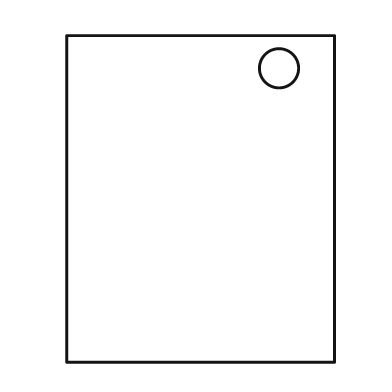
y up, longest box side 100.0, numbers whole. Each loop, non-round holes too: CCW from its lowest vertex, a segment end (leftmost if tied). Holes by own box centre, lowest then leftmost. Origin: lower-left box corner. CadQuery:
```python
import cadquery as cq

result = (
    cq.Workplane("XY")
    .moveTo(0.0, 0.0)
    .lineTo(82.0, 0.0)
    .lineTo(82.0, 100.0)
    .lineTo(0.0, 100.0)
    .close()
    .moveTo(65.0, 90.0)
    .circle(6.0)
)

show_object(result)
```